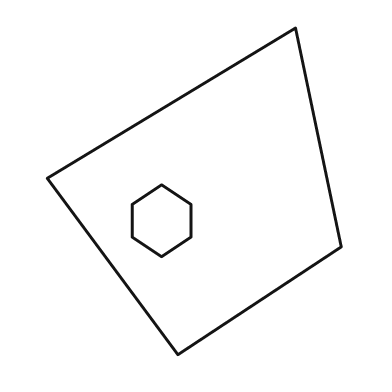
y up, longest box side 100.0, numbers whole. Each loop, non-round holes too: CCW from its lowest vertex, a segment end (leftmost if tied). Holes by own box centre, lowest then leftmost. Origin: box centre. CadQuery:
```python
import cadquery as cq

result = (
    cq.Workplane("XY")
    .moveTo(-5.0, -50.0)
    .lineTo(45.0, -17.0)
    .lineTo(31.0, 50.0)
    .lineTo(-45.0, 4.0)
    .close()
    .moveTo(-10.0, -20.0)
    .lineTo(-1.0, -14.0)
    .lineTo(-1.0, -4.0)
    .lineTo(-10.0, 2.0)
    .lineTo(-19.0, -4.0)
    .lineTo(-19.0, -14.0)
    .close()
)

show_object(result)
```